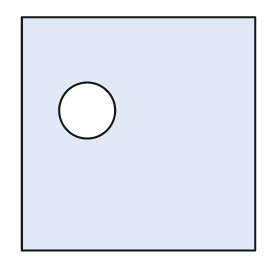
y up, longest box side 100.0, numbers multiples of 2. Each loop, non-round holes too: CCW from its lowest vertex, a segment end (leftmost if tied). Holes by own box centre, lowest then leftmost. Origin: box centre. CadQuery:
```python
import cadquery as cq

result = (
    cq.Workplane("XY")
    .moveTo(-50.0, -50.0)
    .lineTo(50.0, -50.0)
    .lineTo(50.0, 50.0)
    .lineTo(-50.0, 50.0)
    .close()
    .moveTo(-22.0, 10.0)
    .circle(12.0)
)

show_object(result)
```